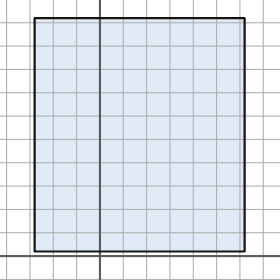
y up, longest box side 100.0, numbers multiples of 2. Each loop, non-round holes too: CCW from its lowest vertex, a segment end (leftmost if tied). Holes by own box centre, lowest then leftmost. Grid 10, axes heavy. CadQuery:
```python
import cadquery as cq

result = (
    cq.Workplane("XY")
    .moveTo(-28.0, 2.0)
    .lineTo(62.0, 2.0)
    .lineTo(62.0, 102.0)
    .lineTo(-28.0, 102.0)
    .close()
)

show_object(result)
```